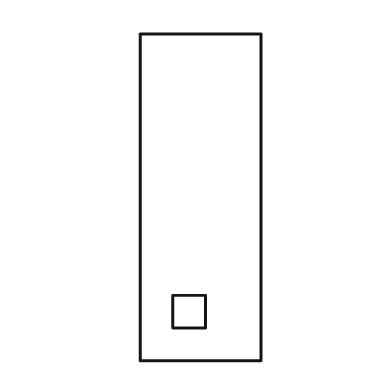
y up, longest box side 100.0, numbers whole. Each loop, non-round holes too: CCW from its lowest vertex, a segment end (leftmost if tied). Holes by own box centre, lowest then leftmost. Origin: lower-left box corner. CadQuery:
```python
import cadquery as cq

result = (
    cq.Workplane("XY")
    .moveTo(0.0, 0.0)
    .lineTo(37.0, 0.0)
    .lineTo(37.0, 100.0)
    .lineTo(0.0, 100.0)
    .close()
    .moveTo(10.0, 10.0)
    .lineTo(20.0, 10.0)
    .lineTo(20.0, 20.0)
    .lineTo(10.0, 20.0)
    .close()
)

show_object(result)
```